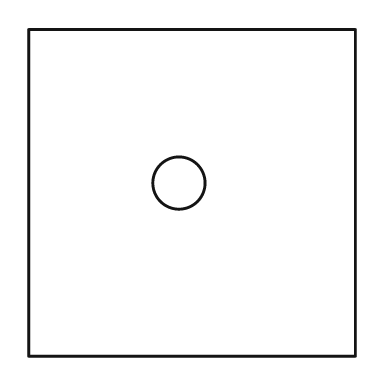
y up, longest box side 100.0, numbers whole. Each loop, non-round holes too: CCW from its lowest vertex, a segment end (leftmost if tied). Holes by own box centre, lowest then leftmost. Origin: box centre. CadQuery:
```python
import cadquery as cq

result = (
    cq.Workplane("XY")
    .moveTo(-50.0, -50.0)
    .lineTo(50.0, -50.0)
    .lineTo(50.0, 50.0)
    .lineTo(-50.0, 50.0)
    .close()
    .moveTo(-4.0, 3.0)
    .circle(8.0)
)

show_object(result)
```